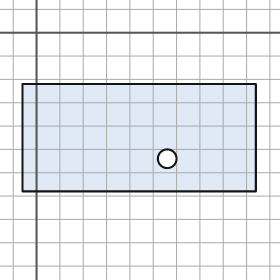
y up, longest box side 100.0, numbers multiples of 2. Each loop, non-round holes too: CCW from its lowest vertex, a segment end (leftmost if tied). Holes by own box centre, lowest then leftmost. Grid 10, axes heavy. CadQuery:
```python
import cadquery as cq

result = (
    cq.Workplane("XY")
    .moveTo(-6.0, -68.0)
    .lineTo(94.0, -68.0)
    .lineTo(94.0, -22.0)
    .lineTo(-6.0, -22.0)
    .close()
    .moveTo(56.0, -54.0)
    .circle(4.0)
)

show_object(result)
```